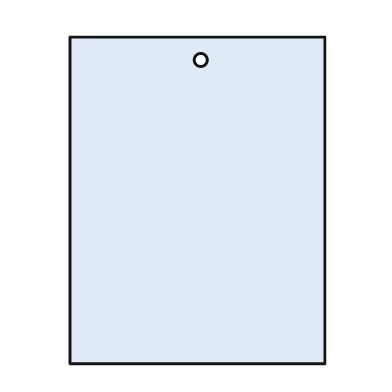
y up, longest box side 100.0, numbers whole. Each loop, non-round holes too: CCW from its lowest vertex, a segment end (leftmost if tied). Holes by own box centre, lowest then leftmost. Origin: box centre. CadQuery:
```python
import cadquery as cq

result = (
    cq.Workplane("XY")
    .moveTo(-39.0, -50.0)
    .lineTo(39.0, -50.0)
    .lineTo(39.0, 50.0)
    .lineTo(-39.0, 50.0)
    .close()
    .moveTo(1.0, 43.0)
    .circle(2.0)
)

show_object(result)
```